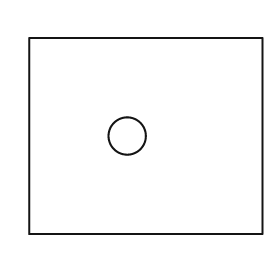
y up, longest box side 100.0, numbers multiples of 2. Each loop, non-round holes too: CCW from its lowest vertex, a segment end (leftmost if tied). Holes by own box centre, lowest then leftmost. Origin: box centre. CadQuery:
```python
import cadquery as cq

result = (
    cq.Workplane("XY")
    .moveTo(-50.0, -42.0)
    .lineTo(50.0, -42.0)
    .lineTo(50.0, 42.0)
    .lineTo(-50.0, 42.0)
    .close()
    .moveTo(-8.0, 0.0)
    .circle(8.0)
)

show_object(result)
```